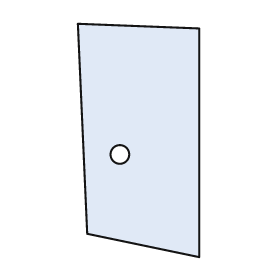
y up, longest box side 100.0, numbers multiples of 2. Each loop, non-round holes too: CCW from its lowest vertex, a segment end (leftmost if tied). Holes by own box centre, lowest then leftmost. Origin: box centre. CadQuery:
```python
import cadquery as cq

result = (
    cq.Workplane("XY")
    .moveTo(26.0, -50.0)
    .lineTo(26.0, 48.0)
    .lineTo(-26.0, 50.0)
    .lineTo(-22.0, -40.0)
    .close()
    .moveTo(-8.0, -6.0)
    .circle(4.0)
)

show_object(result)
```